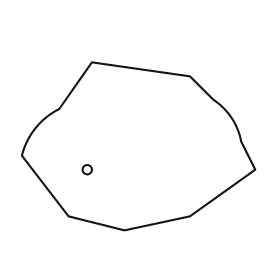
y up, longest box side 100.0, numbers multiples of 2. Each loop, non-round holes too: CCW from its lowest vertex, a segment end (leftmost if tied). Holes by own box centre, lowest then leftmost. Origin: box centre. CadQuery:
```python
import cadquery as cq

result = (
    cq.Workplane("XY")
    .moveTo(-6.0, -36.0)
    .lineTo(22.0, -30.0)
    .lineTo(50.0, -10.0)
    .lineTo(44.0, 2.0)
    .threePointArc((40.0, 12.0), (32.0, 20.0))
    .lineTo(22.0, 30.0)
    .lineTo(-20.0, 36.0)
    .lineTo(-34.0, 16.0)
    .threePointArc((-44.0, 8.0), (-50.0, -4.0))
    .lineTo(-30.0, -30.0)
    .close()
    .moveTo(-22.0, -10.0)
    .circle(2.0)
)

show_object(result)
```